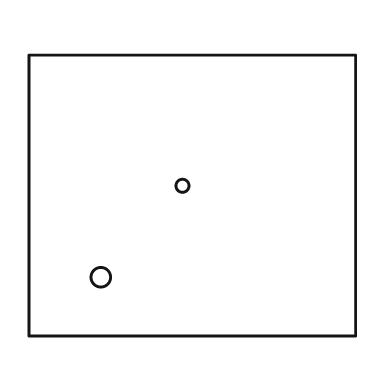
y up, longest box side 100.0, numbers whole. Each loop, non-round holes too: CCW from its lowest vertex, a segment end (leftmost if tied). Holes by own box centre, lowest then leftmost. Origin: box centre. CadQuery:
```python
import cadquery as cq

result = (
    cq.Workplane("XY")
    .moveTo(-50.0, -43.0)
    .lineTo(50.0, -43.0)
    .lineTo(50.0, 43.0)
    .lineTo(-50.0, 43.0)
    .close()
    .moveTo(-28.0, -25.0)
    .circle(3.0)
    .moveTo(-3.0, 3.0)
    .circle(2.0)
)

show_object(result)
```